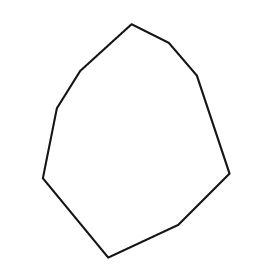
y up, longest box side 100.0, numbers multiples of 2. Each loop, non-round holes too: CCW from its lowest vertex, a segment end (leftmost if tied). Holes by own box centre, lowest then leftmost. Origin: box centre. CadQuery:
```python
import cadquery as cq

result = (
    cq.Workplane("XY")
    .moveTo(-12.0, -50.0)
    .lineTo(18.0, -36.0)
    .lineTo(40.0, -14.0)
    .lineTo(26.0, 28.0)
    .lineTo(14.0, 42.0)
    .lineTo(-2.0, 50.0)
    .lineTo(-24.0, 30.0)
    .lineTo(-34.0, 14.0)
    .lineTo(-40.0, -16.0)
    .close()
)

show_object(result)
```